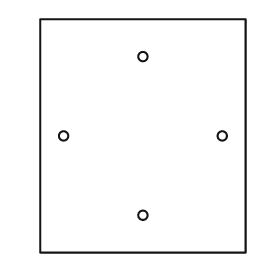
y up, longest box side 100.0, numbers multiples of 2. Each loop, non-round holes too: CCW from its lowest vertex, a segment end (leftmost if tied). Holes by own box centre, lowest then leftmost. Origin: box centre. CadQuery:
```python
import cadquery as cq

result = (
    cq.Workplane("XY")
    .moveTo(-44.0, -50.0)
    .lineTo(44.0, -50.0)
    .lineTo(44.0, 50.0)
    .lineTo(-44.0, 50.0)
    .close()
    .moveTo(0.0, -34.0)
    .circle(2.0)
    .moveTo(-34.0, 0.0)
    .circle(2.0)
    .moveTo(34.0, 0.0)
    .circle(2.0)
    .moveTo(0.0, 34.0)
    .circle(2.0)
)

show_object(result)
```